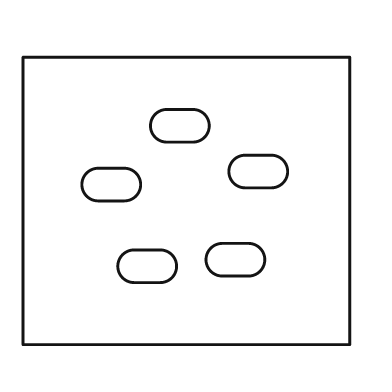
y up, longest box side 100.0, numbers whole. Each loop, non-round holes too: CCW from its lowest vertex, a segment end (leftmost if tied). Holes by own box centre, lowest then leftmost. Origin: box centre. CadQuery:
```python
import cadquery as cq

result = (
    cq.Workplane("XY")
    .moveTo(-50.0, -44.0)
    .lineTo(50.0, -44.0)
    .lineTo(50.0, 44.0)
    .lineTo(-50.0, 44.0)
    .close()
    .moveTo(-16.0, -25.0)
    .lineTo(-8.0, -25.0)
    .threePointArc((-3.0, -20.0), (-8.0, -15.0))
    .lineTo(-16.0, -15.0)
    .threePointArc((-21.0, -20.0), (-16.0, -25.0))
    .close()
    .moveTo(11.0, -23.0)
    .lineTo(19.0, -23.0)
    .threePointArc((24.0, -18.0), (19.0, -13.0))
    .lineTo(11.0, -13.0)
    .threePointArc((6.0, -18.0), (11.0, -23.0))
    .close()
    .moveTo(-27.0, 0.0)
    .lineTo(-19.0, 0.0)
    .threePointArc((-14.0, 5.0), (-19.0, 10.0))
    .lineTo(-27.0, 10.0)
    .threePointArc((-32.0, 5.0), (-27.0, 0.0))
    .close()
    .moveTo(18.0, 4.0)
    .lineTo(26.0, 4.0)
    .threePointArc((31.0, 9.0), (26.0, 14.0))
    .lineTo(18.0, 14.0)
    .threePointArc((13.0, 9.0), (18.0, 4.0))
    .close()
    .moveTo(-6.0, 18.0)
    .lineTo(2.0, 18.0)
    .threePointArc((7.0, 23.0), (2.0, 28.0))
    .lineTo(-6.0, 28.0)
    .threePointArc((-11.0, 23.0), (-6.0, 18.0))
    .close()
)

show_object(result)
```